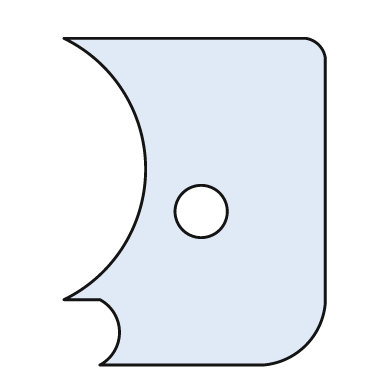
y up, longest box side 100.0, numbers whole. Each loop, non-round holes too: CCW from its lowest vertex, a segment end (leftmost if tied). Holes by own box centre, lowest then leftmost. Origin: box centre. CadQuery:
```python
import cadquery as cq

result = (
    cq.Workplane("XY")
    .moveTo(-29.0, -50.0)
    .lineTo(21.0, -50.0)
    .threePointArc((34.0, -44.0), (40.0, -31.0))
    .lineTo(40.0, 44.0)
    .threePointArc((38.0, 48.0), (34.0, 50.0))
    .lineTo(-40.0, 50.0)
    .threePointArc((-15.0, 10.0), (-40.0, -30.0))
    .lineTo(-29.0, -30.0)
    .threePointArc((-23.0, -40.0), (-29.0, -50.0))
    .close()
    .moveTo(2.0, -3.0)
    .circle(8.0)
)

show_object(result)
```